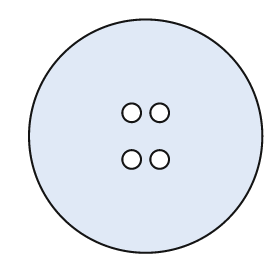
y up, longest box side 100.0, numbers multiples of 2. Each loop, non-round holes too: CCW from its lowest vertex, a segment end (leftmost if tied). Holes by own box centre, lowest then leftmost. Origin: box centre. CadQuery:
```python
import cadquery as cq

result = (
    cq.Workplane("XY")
    .moveTo(0.0, 0.0)
    .circle(50.0)
    .moveTo(-6.0, -10.0)
    .circle(4.0)
    .moveTo(6.0, -10.0)
    .circle(4.0)
    .moveTo(-6.0, 10.0)
    .circle(4.0)
    .moveTo(6.0, 10.0)
    .circle(4.0)
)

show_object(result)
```